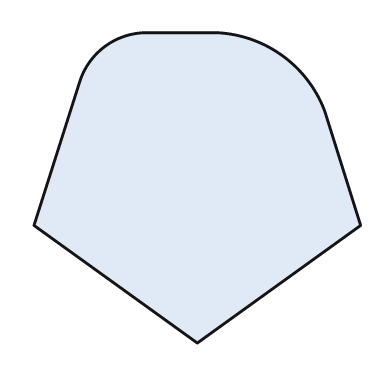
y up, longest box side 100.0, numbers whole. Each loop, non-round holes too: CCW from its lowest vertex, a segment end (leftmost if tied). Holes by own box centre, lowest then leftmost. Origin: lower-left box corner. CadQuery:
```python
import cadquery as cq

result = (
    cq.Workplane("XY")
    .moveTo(50.0, 0.0)
    .lineTo(100.0, 36.0)
    .lineTo(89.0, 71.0)
    .threePointArc((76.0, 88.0), (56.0, 95.0))
    .lineTo(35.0, 95.0)
    .threePointArc((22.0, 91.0), (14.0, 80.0))
    .lineTo(0.0, 36.0)
    .close()
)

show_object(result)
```